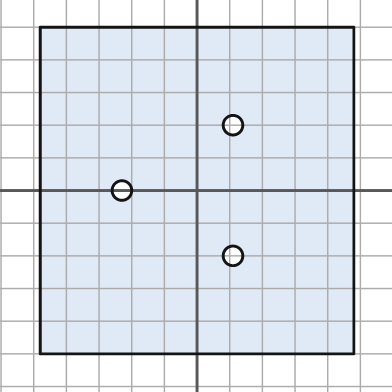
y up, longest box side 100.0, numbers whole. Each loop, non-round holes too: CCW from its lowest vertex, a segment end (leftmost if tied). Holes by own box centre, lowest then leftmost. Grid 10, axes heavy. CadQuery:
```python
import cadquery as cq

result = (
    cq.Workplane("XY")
    .moveTo(-48.0, -50.0)
    .lineTo(48.0, -50.0)
    .lineTo(48.0, 50.0)
    .lineTo(-48.0, 50.0)
    .close()
    .moveTo(11.0, -20.0)
    .circle(3.0)
    .moveTo(-23.0, 0.0)
    .circle(3.0)
    .moveTo(11.0, 20.0)
    .circle(3.0)
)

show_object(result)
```